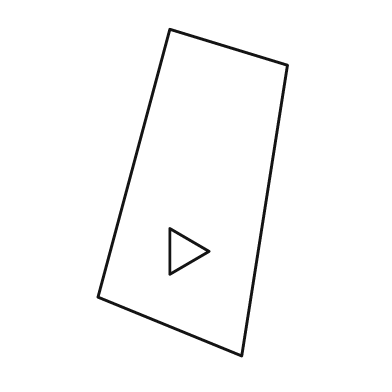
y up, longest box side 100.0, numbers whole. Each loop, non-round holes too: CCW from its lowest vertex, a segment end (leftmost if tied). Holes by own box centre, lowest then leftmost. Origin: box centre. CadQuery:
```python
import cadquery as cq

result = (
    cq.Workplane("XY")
    .moveTo(15.0, -50.0)
    .lineTo(29.0, 39.0)
    .lineTo(-7.0, 50.0)
    .lineTo(-29.0, -32.0)
    .close()
    .moveTo(-7.0, -25.0)
    .lineTo(5.0, -18.0)
    .lineTo(-7.0, -11.0)
    .close()
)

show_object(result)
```